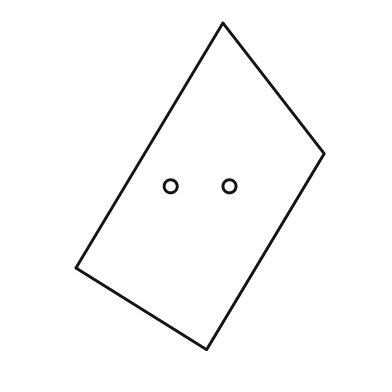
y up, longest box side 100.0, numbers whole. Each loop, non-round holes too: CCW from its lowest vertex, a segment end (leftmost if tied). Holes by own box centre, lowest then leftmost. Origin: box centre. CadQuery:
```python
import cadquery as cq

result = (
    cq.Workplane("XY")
    .moveTo(2.0, -50.0)
    .lineTo(38.0, 10.0)
    .lineTo(7.0, 50.0)
    .lineTo(-38.0, -25.0)
    .close()
    .moveTo(-9.0, 0.0)
    .circle(2.0)
    .moveTo(9.0, 0.0)
    .circle(2.0)
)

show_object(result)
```